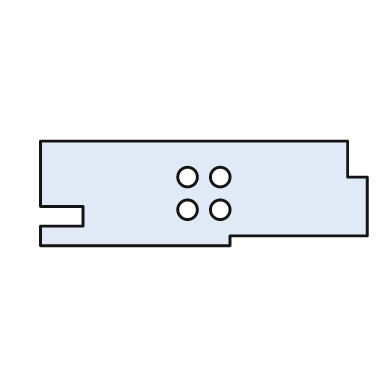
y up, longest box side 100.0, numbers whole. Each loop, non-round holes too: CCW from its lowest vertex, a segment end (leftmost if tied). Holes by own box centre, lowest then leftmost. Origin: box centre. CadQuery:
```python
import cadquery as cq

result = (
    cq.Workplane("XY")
    .moveTo(-50.0, -16.0)
    .lineTo(8.0, -16.0)
    .lineTo(8.0, -13.0)
    .lineTo(50.0, -13.0)
    .lineTo(50.0, 5.0)
    .lineTo(44.0, 5.0)
    .lineTo(44.0, 16.0)
    .lineTo(-50.0, 16.0)
    .lineTo(-50.0, -4.0)
    .lineTo(-37.0, -4.0)
    .lineTo(-37.0, -10.0)
    .lineTo(-50.0, -10.0)
    .close()
    .moveTo(-5.0, -5.0)
    .circle(3.0)
    .moveTo(5.0, -5.0)
    .circle(3.0)
    .moveTo(-5.0, 5.0)
    .circle(3.0)
    .moveTo(5.0, 5.0)
    .circle(3.0)
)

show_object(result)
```